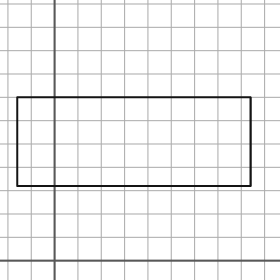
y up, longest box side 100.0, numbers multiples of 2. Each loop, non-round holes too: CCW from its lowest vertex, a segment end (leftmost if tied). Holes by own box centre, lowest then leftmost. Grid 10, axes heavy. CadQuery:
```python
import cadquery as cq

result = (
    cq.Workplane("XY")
    .moveTo(-16.0, 32.0)
    .lineTo(84.0, 32.0)
    .lineTo(84.0, 70.0)
    .lineTo(-16.0, 70.0)
    .close()
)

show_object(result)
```